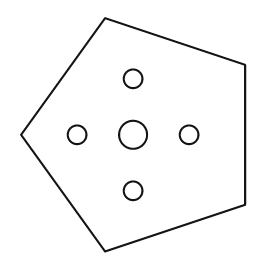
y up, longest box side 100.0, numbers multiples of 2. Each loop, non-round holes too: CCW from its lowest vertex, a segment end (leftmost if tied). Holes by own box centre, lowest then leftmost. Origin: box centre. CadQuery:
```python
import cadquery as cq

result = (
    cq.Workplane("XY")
    .moveTo(-12.0, -50.0)
    .lineTo(48.0, -30.0)
    .lineTo(48.0, 30.0)
    .lineTo(-12.0, 50.0)
    .lineTo(-48.0, 0.0)
    .close()
    .moveTo(0.0, -24.0)
    .circle(4.0)
    .moveTo(-24.0, 0.0)
    .circle(4.0)
    .moveTo(0.0, 0.0)
    .circle(6.0)
    .moveTo(24.0, 0.0)
    .circle(4.0)
    .moveTo(0.0, 24.0)
    .circle(4.0)
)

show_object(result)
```